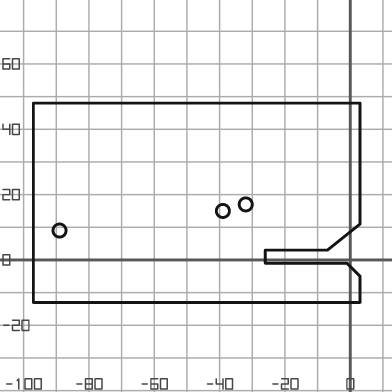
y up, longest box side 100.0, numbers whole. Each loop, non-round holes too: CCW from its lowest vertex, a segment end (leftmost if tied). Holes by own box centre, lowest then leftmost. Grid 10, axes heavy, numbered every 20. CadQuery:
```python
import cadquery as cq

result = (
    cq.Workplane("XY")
    .moveTo(-97.0, -13.0)
    .lineTo(3.0, -13.0)
    .lineTo(3.0, -5.0)
    .lineTo(-1.0, -1.0)
    .lineTo(-26.0, -1.0)
    .lineTo(-26.0, 3.0)
    .lineTo(-7.0, 3.0)
    .lineTo(3.0, 11.0)
    .lineTo(3.0, 48.0)
    .lineTo(-97.0, 48.0)
    .close()
    .moveTo(-89.0, 9.0)
    .circle(2.0)
    .moveTo(-39.0, 15.0)
    .circle(2.0)
    .moveTo(-32.0, 17.0)
    .circle(2.0)
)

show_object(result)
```